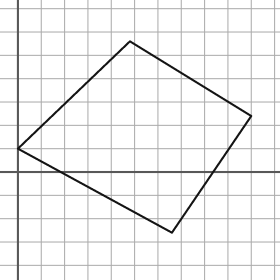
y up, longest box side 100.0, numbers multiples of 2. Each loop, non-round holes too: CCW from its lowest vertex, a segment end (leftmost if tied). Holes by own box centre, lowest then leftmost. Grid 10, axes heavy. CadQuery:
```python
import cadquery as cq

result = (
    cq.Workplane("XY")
    .moveTo(66.0, -26.0)
    .lineTo(100.0, 24.0)
    .lineTo(48.0, 56.0)
    .lineTo(0.0, 10.0)
    .close()
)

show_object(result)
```